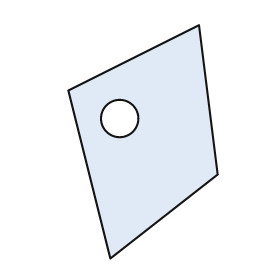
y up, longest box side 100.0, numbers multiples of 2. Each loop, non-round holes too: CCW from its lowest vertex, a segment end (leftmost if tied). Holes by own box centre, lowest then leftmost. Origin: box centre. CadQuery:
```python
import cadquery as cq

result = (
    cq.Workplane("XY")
    .moveTo(-14.0, -50.0)
    .lineTo(32.0, -14.0)
    .lineTo(24.0, 50.0)
    .lineTo(-32.0, 22.0)
    .close()
    .moveTo(-10.0, 10.0)
    .circle(8.0)
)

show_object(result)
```